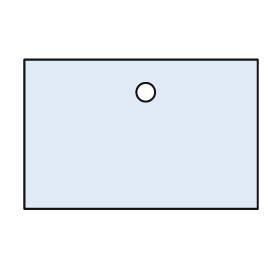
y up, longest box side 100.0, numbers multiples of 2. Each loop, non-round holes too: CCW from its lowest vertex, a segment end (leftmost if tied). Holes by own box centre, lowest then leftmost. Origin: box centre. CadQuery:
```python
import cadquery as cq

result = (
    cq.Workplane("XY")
    .moveTo(-50.0, -32.0)
    .lineTo(50.0, -32.0)
    .lineTo(50.0, 32.0)
    .lineTo(-50.0, 32.0)
    .close()
    .moveTo(2.0, 18.0)
    .circle(4.0)
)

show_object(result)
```